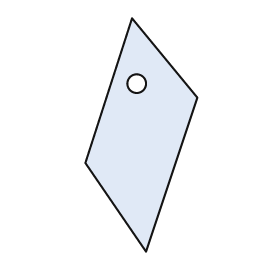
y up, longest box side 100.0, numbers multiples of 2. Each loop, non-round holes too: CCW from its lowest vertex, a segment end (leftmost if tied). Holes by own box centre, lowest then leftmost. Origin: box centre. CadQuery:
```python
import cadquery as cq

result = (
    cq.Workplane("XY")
    .moveTo(2.0, -50.0)
    .lineTo(24.0, 16.0)
    .lineTo(-4.0, 50.0)
    .lineTo(-24.0, -12.0)
    .close()
    .moveTo(-2.0, 22.0)
    .circle(4.0)
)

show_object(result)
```